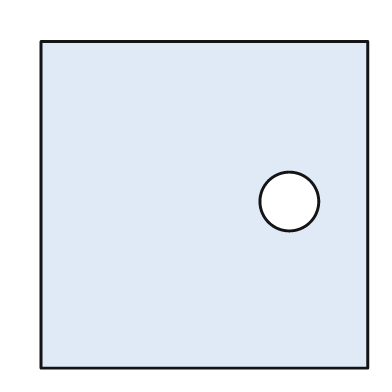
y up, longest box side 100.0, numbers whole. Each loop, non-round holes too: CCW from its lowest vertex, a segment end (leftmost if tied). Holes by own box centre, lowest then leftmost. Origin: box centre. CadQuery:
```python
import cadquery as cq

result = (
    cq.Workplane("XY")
    .moveTo(-50.0, -50.0)
    .lineTo(50.0, -50.0)
    .lineTo(50.0, 50.0)
    .lineTo(-50.0, 50.0)
    .close()
    .moveTo(26.0, 1.0)
    .circle(9.0)
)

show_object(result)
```